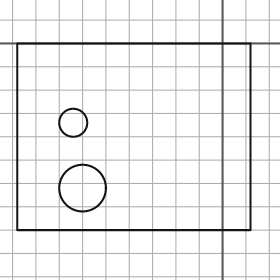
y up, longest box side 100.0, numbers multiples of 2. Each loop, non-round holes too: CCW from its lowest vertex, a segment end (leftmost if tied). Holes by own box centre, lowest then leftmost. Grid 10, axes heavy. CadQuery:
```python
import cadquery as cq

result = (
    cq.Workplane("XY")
    .moveTo(-88.0, -80.0)
    .lineTo(12.0, -80.0)
    .lineTo(12.0, 0.0)
    .lineTo(-88.0, 0.0)
    .close()
    .moveTo(-60.0, -62.0)
    .circle(10.0)
    .moveTo(-64.0, -34.0)
    .circle(6.0)
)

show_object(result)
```